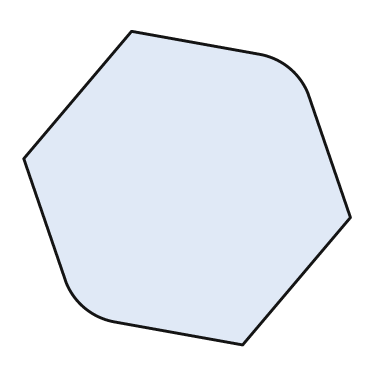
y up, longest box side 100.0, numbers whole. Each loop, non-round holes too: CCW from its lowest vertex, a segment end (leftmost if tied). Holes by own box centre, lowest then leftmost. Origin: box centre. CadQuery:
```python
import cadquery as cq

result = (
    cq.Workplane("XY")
    .moveTo(17.0, -48.0)
    .lineTo(50.0, -9.0)
    .lineTo(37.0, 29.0)
    .threePointArc((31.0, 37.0), (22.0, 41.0))
    .lineTo(-17.0, 48.0)
    .lineTo(-50.0, 9.0)
    .lineTo(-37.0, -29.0)
    .threePointArc((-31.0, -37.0), (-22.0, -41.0))
    .close()
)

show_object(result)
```